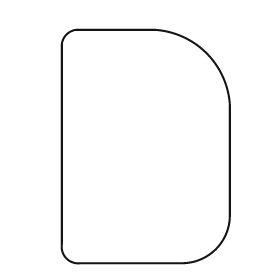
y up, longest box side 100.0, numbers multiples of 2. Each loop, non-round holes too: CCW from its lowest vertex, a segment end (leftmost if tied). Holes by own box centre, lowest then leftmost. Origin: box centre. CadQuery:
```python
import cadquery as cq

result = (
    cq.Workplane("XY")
    .moveTo(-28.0, -50.0)
    .lineTo(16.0, -50.0)
    .threePointArc((30.0, -44.0), (36.0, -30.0))
    .lineTo(36.0, 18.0)
    .threePointArc((26.0, 40.0), (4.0, 50.0))
    .lineTo(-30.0, 50.0)
    .threePointArc((-34.0, 48.0), (-36.0, 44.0))
    .lineTo(-36.0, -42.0)
    .threePointArc((-34.0, -48.0), (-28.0, -50.0))
    .close()
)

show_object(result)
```